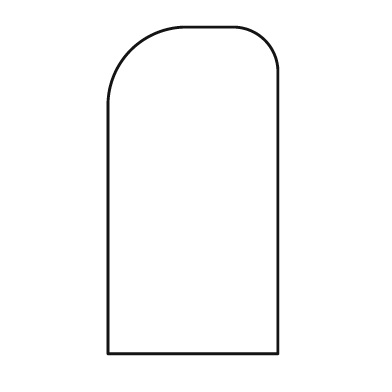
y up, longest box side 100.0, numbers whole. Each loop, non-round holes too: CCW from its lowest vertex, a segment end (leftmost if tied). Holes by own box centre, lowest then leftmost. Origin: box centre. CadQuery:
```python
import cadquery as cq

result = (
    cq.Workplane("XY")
    .moveTo(-26.0, -50.0)
    .lineTo(26.0, -50.0)
    .lineTo(26.0, 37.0)
    .threePointArc((22.0, 46.0), (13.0, 50.0))
    .lineTo(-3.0, 50.0)
    .threePointArc((-19.0, 43.0), (-26.0, 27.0))
    .close()
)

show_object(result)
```